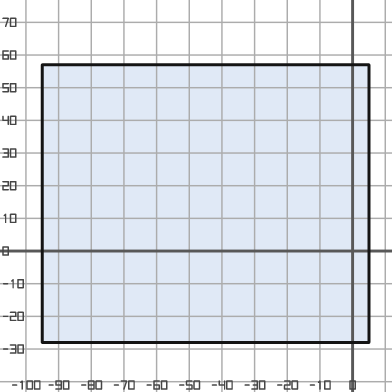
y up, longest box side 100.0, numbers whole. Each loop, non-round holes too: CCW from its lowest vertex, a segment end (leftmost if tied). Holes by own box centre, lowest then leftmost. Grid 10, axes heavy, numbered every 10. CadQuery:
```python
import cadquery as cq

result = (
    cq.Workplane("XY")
    .moveTo(-95.0, -28.0)
    .lineTo(5.0, -28.0)
    .lineTo(5.0, 57.0)
    .lineTo(-95.0, 57.0)
    .close()
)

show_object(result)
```